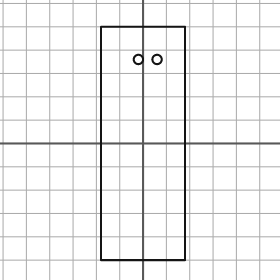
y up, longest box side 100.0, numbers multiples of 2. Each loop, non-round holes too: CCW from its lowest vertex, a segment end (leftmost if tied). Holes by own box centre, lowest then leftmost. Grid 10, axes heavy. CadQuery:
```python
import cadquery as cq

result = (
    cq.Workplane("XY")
    .moveTo(-18.0, -50.0)
    .lineTo(18.0, -50.0)
    .lineTo(18.0, 50.0)
    .lineTo(-18.0, 50.0)
    .close()
    .moveTo(-2.0, 36.0)
    .circle(2.0)
    .moveTo(6.0, 36.0)
    .circle(2.0)
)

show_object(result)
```